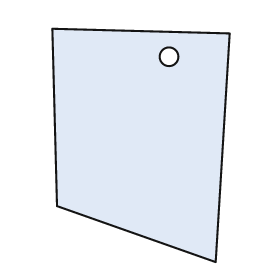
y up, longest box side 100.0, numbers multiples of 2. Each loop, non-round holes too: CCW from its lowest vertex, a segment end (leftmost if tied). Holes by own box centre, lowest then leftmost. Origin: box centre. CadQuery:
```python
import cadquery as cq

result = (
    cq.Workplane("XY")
    .moveTo(32.0, -50.0)
    .lineTo(38.0, 48.0)
    .lineTo(-38.0, 50.0)
    .lineTo(-36.0, -26.0)
    .close()
    .moveTo(12.0, 38.0)
    .circle(4.0)
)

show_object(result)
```